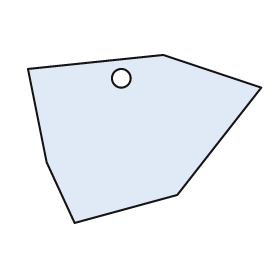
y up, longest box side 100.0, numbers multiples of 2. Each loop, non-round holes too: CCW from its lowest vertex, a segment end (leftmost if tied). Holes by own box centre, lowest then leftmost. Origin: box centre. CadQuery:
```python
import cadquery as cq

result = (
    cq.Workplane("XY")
    .moveTo(-30.0, -36.0)
    .lineTo(14.0, -24.0)
    .lineTo(50.0, 22.0)
    .lineTo(8.0, 36.0)
    .lineTo(-50.0, 30.0)
    .lineTo(-42.0, -10.0)
    .close()
    .moveTo(-10.0, 26.0)
    .circle(4.0)
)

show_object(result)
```